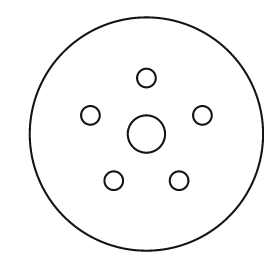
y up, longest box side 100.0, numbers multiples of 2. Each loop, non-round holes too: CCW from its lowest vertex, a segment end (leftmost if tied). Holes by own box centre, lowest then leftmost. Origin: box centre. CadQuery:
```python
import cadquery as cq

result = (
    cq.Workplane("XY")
    .moveTo(0.0, 0.0)
    .circle(50.0)
    .moveTo(-14.0, -20.0)
    .circle(4.0)
    .moveTo(14.0, -20.0)
    .circle(4.0)
    .moveTo(0.0, 0.0)
    .circle(8.0)
    .moveTo(-24.0, 8.0)
    .circle(4.0)
    .moveTo(24.0, 8.0)
    .circle(4.0)
    .moveTo(0.0, 24.0)
    .circle(4.0)
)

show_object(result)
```